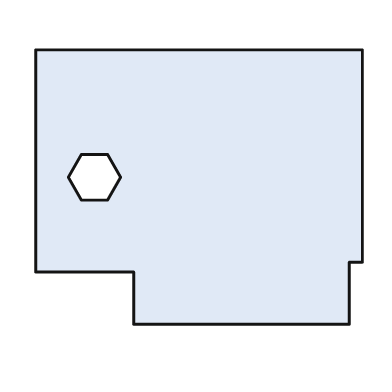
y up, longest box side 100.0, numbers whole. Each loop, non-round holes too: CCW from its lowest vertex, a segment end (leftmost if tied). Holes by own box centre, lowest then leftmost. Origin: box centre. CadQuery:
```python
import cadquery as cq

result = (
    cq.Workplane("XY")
    .moveTo(-20.0, -42.0)
    .lineTo(46.0, -42.0)
    .lineTo(46.0, -23.0)
    .lineTo(50.0, -23.0)
    .lineTo(50.0, 42.0)
    .lineTo(-50.0, 42.0)
    .lineTo(-50.0, -26.0)
    .lineTo(-20.0, -26.0)
    .close()
    .moveTo(-36.0, -4.0)
    .lineTo(-28.0, -4.0)
    .lineTo(-24.0, 3.0)
    .lineTo(-28.0, 10.0)
    .lineTo(-36.0, 10.0)
    .lineTo(-40.0, 3.0)
    .close()
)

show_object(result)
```